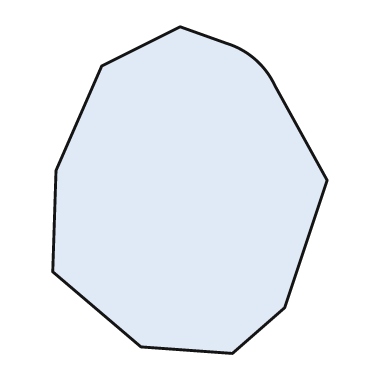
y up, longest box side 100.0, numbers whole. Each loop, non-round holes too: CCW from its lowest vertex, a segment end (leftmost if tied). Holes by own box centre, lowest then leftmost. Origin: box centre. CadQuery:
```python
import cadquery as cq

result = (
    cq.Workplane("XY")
    .moveTo(13.0, -50.0)
    .lineTo(29.0, -36.0)
    .lineTo(42.0, 3.0)
    .lineTo(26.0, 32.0)
    .threePointArc((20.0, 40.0), (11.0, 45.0))
    .lineTo(-3.0, 50.0)
    .lineTo(-27.0, 38.0)
    .lineTo(-41.0, 6.0)
    .lineTo(-42.0, -25.0)
    .lineTo(-15.0, -48.0)
    .close()
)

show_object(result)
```